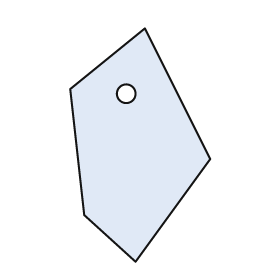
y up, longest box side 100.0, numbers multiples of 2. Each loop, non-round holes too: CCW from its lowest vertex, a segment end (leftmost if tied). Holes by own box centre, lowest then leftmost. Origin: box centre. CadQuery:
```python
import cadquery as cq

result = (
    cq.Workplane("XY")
    .moveTo(-2.0, -50.0)
    .lineTo(30.0, -6.0)
    .lineTo(2.0, 50.0)
    .lineTo(-30.0, 24.0)
    .lineTo(-24.0, -30.0)
    .close()
    .moveTo(-6.0, 22.0)
    .circle(4.0)
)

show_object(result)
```